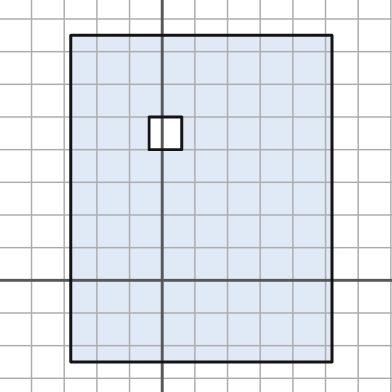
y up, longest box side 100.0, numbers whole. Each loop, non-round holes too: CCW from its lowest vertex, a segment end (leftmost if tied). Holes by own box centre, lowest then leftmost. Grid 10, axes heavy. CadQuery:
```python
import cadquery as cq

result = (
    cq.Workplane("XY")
    .moveTo(-28.0, -25.0)
    .lineTo(52.0, -25.0)
    .lineTo(52.0, 75.0)
    .lineTo(-28.0, 75.0)
    .close()
    .moveTo(-4.0, 40.0)
    .lineTo(6.0, 40.0)
    .lineTo(6.0, 50.0)
    .lineTo(-4.0, 50.0)
    .close()
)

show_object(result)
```